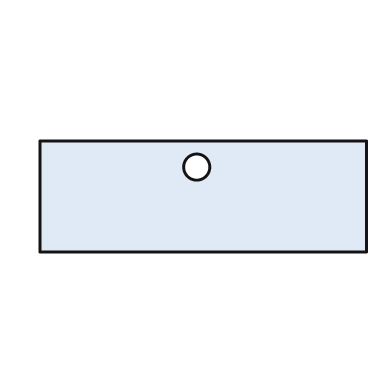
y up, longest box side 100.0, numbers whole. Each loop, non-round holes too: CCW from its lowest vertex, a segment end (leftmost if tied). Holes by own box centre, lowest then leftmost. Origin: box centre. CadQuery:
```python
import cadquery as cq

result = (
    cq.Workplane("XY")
    .moveTo(-50.0, -17.0)
    .lineTo(50.0, -17.0)
    .lineTo(50.0, 17.0)
    .lineTo(-50.0, 17.0)
    .close()
    .moveTo(-2.0, 9.0)
    .circle(4.0)
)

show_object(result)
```